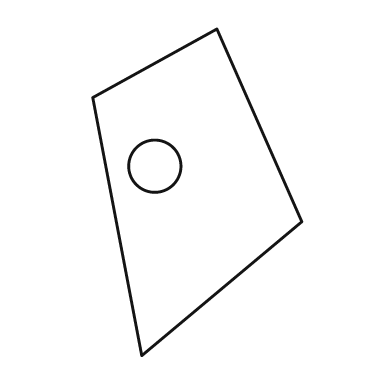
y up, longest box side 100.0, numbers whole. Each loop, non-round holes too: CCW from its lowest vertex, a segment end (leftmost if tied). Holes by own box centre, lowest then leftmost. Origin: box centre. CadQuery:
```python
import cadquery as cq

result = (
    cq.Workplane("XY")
    .moveTo(-17.0, -50.0)
    .lineTo(32.0, -9.0)
    .lineTo(6.0, 50.0)
    .lineTo(-32.0, 29.0)
    .close()
    .moveTo(-13.0, 8.0)
    .circle(8.0)
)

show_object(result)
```